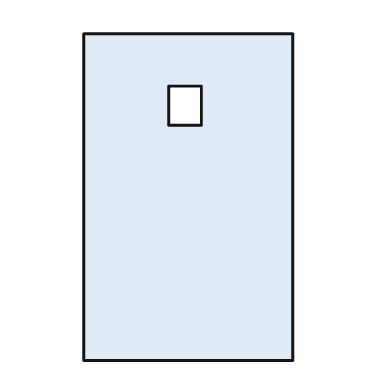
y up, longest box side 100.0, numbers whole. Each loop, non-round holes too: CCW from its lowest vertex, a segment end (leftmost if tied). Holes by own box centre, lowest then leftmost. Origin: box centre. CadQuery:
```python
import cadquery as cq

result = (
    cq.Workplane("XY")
    .moveTo(-32.0, -50.0)
    .lineTo(32.0, -50.0)
    .lineTo(32.0, 50.0)
    .lineTo(-32.0, 50.0)
    .close()
    .moveTo(-6.0, 22.0)
    .lineTo(4.0, 22.0)
    .lineTo(4.0, 34.0)
    .lineTo(-6.0, 34.0)
    .close()
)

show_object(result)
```